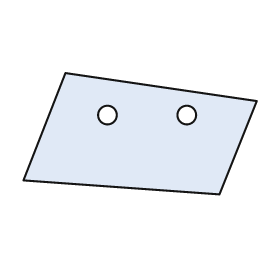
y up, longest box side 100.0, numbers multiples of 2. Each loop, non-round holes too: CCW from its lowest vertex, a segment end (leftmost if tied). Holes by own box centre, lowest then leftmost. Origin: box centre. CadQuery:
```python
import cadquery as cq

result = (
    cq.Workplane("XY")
    .moveTo(34.0, -26.0)
    .lineTo(50.0, 14.0)
    .lineTo(-32.0, 26.0)
    .lineTo(-50.0, -20.0)
    .close()
    .moveTo(-14.0, 8.0)
    .circle(4.0)
    .moveTo(20.0, 8.0)
    .circle(4.0)
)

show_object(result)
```